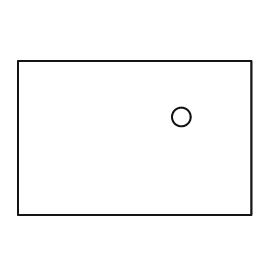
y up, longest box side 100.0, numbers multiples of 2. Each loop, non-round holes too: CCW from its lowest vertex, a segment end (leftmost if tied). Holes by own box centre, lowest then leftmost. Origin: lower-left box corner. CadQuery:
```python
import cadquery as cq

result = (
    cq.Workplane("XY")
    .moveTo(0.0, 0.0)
    .lineTo(100.0, 0.0)
    .lineTo(100.0, 66.0)
    .lineTo(0.0, 66.0)
    .close()
    .moveTo(70.0, 42.0)
    .circle(4.0)
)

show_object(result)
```